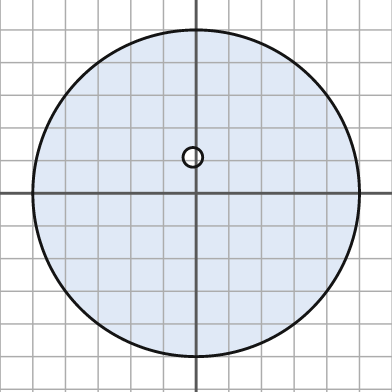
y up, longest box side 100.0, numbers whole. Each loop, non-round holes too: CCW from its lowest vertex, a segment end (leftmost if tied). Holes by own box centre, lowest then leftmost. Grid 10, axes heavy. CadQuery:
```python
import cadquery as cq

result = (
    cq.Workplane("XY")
    .moveTo(0.0, 0.0)
    .circle(50.0)
    .moveTo(-1.0, 11.0)
    .circle(3.0)
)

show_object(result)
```